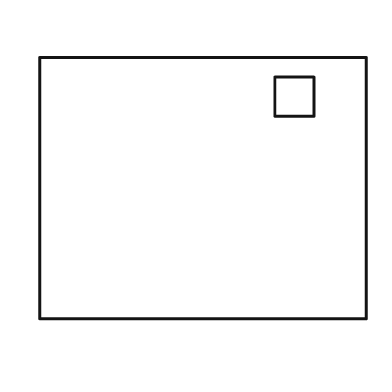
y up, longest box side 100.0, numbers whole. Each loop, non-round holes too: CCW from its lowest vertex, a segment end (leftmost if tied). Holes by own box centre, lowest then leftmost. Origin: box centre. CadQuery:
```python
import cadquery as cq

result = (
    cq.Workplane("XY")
    .moveTo(-50.0, -40.0)
    .lineTo(50.0, -40.0)
    .lineTo(50.0, 40.0)
    .lineTo(-50.0, 40.0)
    .close()
    .moveTo(22.0, 22.0)
    .lineTo(34.0, 22.0)
    .lineTo(34.0, 34.0)
    .lineTo(22.0, 34.0)
    .close()
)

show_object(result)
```